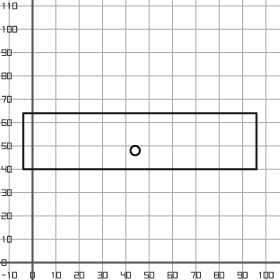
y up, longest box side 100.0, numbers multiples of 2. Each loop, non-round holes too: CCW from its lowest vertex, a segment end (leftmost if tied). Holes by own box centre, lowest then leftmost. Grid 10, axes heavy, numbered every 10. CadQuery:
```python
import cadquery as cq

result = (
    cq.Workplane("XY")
    .moveTo(-4.0, 40.0)
    .lineTo(96.0, 40.0)
    .lineTo(96.0, 64.0)
    .lineTo(-4.0, 64.0)
    .close()
    .moveTo(44.0, 48.0)
    .circle(2.0)
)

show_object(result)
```